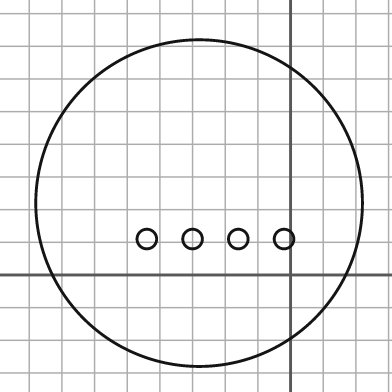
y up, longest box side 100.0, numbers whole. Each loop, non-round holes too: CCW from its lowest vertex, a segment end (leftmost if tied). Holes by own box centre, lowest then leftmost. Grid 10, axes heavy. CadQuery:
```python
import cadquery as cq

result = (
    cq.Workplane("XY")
    .moveTo(-28.0, 22.0)
    .circle(50.0)
    .moveTo(-44.0, 11.0)
    .circle(3.0)
    .moveTo(-30.0, 11.0)
    .circle(3.0)
    .moveTo(-16.0, 11.0)
    .circle(3.0)
    .moveTo(-2.0, 11.0)
    .circle(3.0)
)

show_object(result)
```